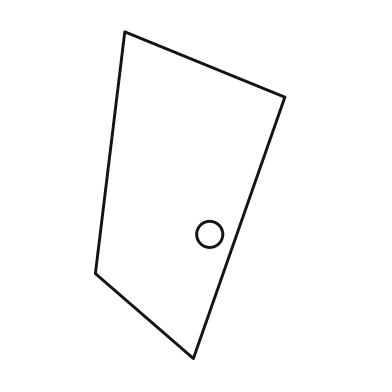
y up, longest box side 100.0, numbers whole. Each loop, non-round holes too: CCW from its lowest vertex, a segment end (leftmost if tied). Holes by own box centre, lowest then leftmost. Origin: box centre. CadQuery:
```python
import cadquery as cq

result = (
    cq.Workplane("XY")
    .moveTo(1.0, -50.0)
    .lineTo(29.0, 30.0)
    .lineTo(-20.0, 50.0)
    .lineTo(-29.0, -24.0)
    .close()
    .moveTo(6.0, -12.0)
    .circle(4.0)
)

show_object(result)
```